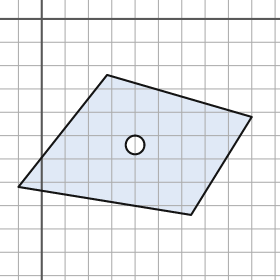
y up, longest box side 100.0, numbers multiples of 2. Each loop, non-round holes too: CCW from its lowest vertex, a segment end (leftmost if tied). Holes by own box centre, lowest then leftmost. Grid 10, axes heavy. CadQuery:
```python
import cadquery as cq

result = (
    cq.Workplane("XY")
    .moveTo(64.0, -84.0)
    .lineTo(90.0, -42.0)
    .lineTo(28.0, -24.0)
    .lineTo(-10.0, -72.0)
    .close()
    .moveTo(40.0, -54.0)
    .circle(4.0)
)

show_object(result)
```